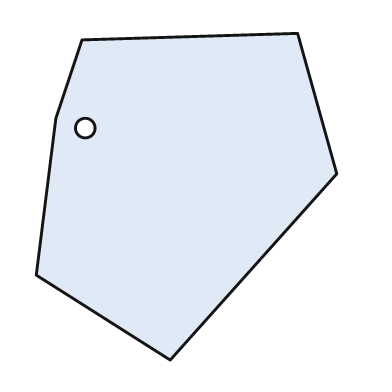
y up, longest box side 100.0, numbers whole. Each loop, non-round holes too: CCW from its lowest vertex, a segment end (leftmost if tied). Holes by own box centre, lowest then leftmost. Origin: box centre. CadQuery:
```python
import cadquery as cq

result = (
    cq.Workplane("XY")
    .moveTo(-5.0, -50.0)
    .lineTo(46.0, 7.0)
    .lineTo(34.0, 50.0)
    .lineTo(-32.0, 48.0)
    .lineTo(-40.0, 24.0)
    .lineTo(-46.0, -24.0)
    .close()
    .moveTo(-31.0, 21.0)
    .circle(3.0)
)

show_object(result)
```